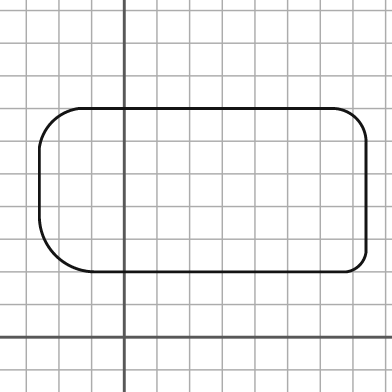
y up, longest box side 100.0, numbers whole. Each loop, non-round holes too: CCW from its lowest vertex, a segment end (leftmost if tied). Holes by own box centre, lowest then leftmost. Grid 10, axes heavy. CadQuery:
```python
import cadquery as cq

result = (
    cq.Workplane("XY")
    .moveTo(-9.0, 20.0)
    .lineTo(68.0, 20.0)
    .threePointArc((72.0, 22.0), (74.0, 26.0))
    .lineTo(74.0, 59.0)
    .threePointArc((71.0, 67.0), (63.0, 70.0))
    .lineTo(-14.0, 70.0)
    .threePointArc((-22.0, 66.0), (-26.0, 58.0))
    .lineTo(-26.0, 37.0)
    .threePointArc((-21.0, 25.0), (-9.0, 20.0))
    .close()
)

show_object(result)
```